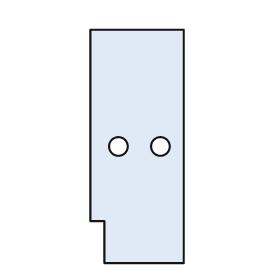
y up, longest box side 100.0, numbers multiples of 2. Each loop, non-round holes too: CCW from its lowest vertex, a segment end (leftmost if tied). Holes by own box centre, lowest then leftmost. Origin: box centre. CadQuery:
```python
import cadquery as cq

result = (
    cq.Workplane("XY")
    .moveTo(-14.0, -50.0)
    .lineTo(20.0, -50.0)
    .lineTo(20.0, 50.0)
    .lineTo(-20.0, 50.0)
    .lineTo(-20.0, -32.0)
    .lineTo(-14.0, -32.0)
    .close()
    .moveTo(-8.0, 0.0)
    .circle(4.0)
    .moveTo(10.0, 0.0)
    .circle(4.0)
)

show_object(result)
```